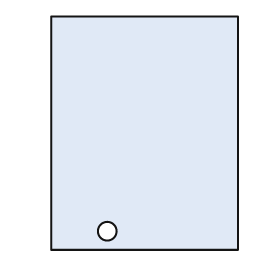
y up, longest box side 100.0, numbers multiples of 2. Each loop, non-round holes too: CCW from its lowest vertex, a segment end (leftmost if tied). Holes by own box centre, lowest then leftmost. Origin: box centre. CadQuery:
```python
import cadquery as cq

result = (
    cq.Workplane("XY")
    .moveTo(-40.0, -50.0)
    .lineTo(40.0, -50.0)
    .lineTo(40.0, 50.0)
    .lineTo(-40.0, 50.0)
    .close()
    .moveTo(-16.0, -42.0)
    .circle(4.0)
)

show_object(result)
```